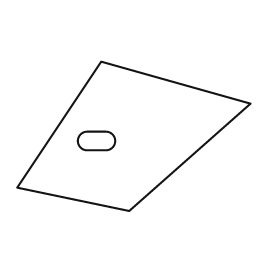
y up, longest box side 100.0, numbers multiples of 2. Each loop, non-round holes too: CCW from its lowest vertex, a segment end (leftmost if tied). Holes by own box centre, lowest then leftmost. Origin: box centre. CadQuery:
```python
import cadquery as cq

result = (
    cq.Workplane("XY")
    .moveTo(-2.0, -32.0)
    .lineTo(50.0, 14.0)
    .lineTo(-14.0, 32.0)
    .lineTo(-50.0, -22.0)
    .close()
    .moveTo(-20.0, -6.0)
    .lineTo(-12.0, -6.0)
    .threePointArc((-8.0, -2.0), (-12.0, 2.0))
    .lineTo(-20.0, 2.0)
    .threePointArc((-24.0, -2.0), (-20.0, -6.0))
    .close()
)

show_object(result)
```